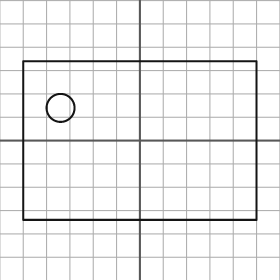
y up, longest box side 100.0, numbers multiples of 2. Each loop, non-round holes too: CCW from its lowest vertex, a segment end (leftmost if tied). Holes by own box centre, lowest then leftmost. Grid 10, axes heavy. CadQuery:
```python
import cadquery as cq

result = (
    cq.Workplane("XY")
    .moveTo(-50.0, -34.0)
    .lineTo(50.0, -34.0)
    .lineTo(50.0, 34.0)
    .lineTo(-50.0, 34.0)
    .close()
    .moveTo(-34.0, 14.0)
    .circle(6.0)
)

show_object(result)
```